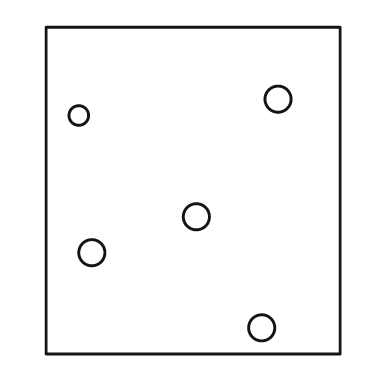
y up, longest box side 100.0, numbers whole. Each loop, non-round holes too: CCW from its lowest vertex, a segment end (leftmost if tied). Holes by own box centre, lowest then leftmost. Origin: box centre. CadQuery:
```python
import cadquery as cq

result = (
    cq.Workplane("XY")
    .moveTo(-45.0, -50.0)
    .lineTo(45.0, -50.0)
    .lineTo(45.0, 50.0)
    .lineTo(-45.0, 50.0)
    .close()
    .moveTo(21.0, -42.0)
    .circle(4.0)
    .moveTo(-31.0, -19.0)
    .circle(4.0)
    .moveTo(1.0, -8.0)
    .circle(4.0)
    .moveTo(-35.0, 23.0)
    .circle(3.0)
    .moveTo(26.0, 28.0)
    .circle(4.0)
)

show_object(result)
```